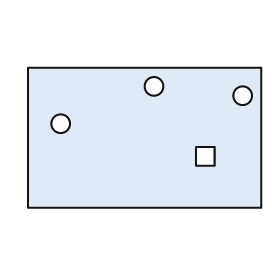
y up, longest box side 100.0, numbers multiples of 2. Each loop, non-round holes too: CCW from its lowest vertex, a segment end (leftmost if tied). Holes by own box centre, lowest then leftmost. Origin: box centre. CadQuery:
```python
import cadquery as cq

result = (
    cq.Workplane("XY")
    .moveTo(-50.0, -30.0)
    .lineTo(50.0, -30.0)
    .lineTo(50.0, 30.0)
    .lineTo(-50.0, 30.0)
    .close()
    .moveTo(22.0, -12.0)
    .lineTo(30.0, -12.0)
    .lineTo(30.0, -4.0)
    .lineTo(22.0, -4.0)
    .close()
    .moveTo(-36.0, 6.0)
    .circle(4.0)
    .moveTo(42.0, 18.0)
    .circle(4.0)
    .moveTo(4.0, 22.0)
    .circle(4.0)
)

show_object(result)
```